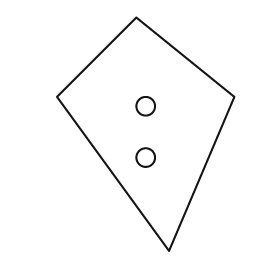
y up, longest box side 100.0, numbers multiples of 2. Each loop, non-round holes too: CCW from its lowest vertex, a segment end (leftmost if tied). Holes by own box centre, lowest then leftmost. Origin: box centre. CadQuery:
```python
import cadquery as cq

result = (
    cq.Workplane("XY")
    .moveTo(10.0, -50.0)
    .lineTo(38.0, 16.0)
    .lineTo(-4.0, 50.0)
    .lineTo(-38.0, 16.0)
    .close()
    .moveTo(0.0, -10.0)
    .circle(4.0)
    .moveTo(0.0, 12.0)
    .circle(4.0)
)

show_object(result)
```